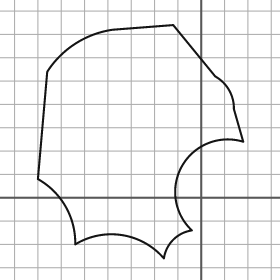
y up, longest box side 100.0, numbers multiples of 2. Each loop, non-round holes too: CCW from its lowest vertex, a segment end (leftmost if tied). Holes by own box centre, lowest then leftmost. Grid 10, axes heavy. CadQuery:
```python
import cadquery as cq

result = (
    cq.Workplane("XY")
    .moveTo(-16.0, -26.0)
    .threePointArc((-12.0, -18.0), (-4.0, -14.0))
    .threePointArc((-8.0, 14.0), (18.0, 24.0))
    .lineTo(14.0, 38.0)
    .threePointArc((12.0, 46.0), (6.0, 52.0))
    .lineTo(-12.0, 74.0)
    .lineTo(-38.0, 72.0)
    .threePointArc((-54.0, 66.0), (-66.0, 54.0))
    .lineTo(-70.0, 8.0)
    .threePointArc((-58.0, -4.0), (-54.0, -20.0))
    .threePointArc((-34.0, -16.0), (-16.0, -26.0))
    .close()
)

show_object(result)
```